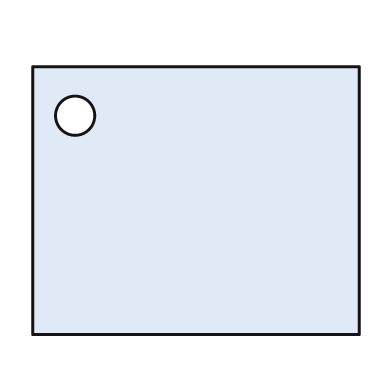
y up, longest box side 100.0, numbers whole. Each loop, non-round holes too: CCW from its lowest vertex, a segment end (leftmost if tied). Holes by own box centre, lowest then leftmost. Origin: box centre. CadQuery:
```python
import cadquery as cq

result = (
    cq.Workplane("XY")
    .moveTo(-50.0, -41.0)
    .lineTo(50.0, -41.0)
    .lineTo(50.0, 41.0)
    .lineTo(-50.0, 41.0)
    .close()
    .moveTo(-37.0, 26.0)
    .circle(6.0)
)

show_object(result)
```